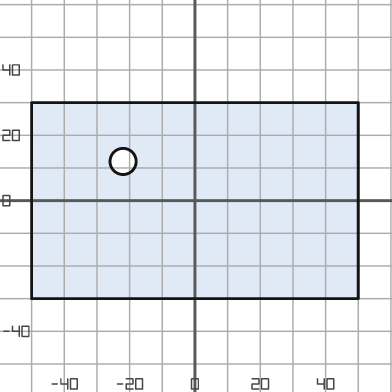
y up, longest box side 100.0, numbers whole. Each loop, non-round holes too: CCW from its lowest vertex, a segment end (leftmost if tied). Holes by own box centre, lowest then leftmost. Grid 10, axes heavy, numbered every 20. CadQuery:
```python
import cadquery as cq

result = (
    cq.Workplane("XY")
    .moveTo(-50.0, -30.0)
    .lineTo(50.0, -30.0)
    .lineTo(50.0, 30.0)
    .lineTo(-50.0, 30.0)
    .close()
    .moveTo(-22.0, 12.0)
    .circle(4.0)
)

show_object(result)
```